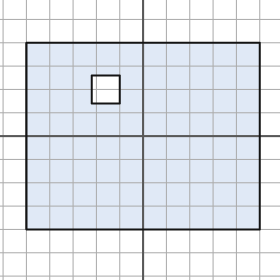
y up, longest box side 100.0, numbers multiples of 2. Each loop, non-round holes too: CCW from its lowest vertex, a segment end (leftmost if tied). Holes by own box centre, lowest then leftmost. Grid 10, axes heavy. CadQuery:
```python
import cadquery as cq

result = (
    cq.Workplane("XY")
    .moveTo(-50.0, -40.0)
    .lineTo(50.0, -40.0)
    .lineTo(50.0, 40.0)
    .lineTo(-50.0, 40.0)
    .close()
    .moveTo(-22.0, 14.0)
    .lineTo(-10.0, 14.0)
    .lineTo(-10.0, 26.0)
    .lineTo(-22.0, 26.0)
    .close()
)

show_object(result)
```